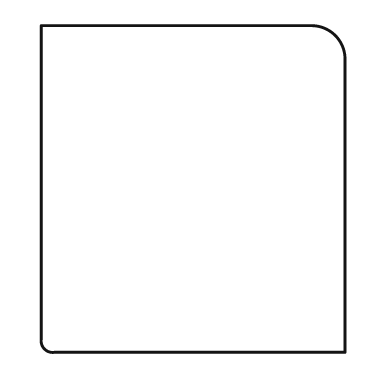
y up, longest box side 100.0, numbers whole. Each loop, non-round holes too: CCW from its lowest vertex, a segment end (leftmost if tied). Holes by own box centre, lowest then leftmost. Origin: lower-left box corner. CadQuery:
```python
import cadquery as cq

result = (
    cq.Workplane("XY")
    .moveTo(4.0, 0.0)
    .lineTo(93.0, 0.0)
    .lineTo(93.0, 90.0)
    .threePointArc((90.0, 97.0), (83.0, 100.0))
    .lineTo(0.0, 100.0)
    .lineTo(0.0, 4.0)
    .threePointArc((1.0, 1.0), (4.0, 0.0))
    .close()
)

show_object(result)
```